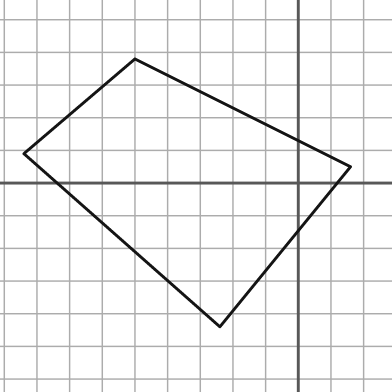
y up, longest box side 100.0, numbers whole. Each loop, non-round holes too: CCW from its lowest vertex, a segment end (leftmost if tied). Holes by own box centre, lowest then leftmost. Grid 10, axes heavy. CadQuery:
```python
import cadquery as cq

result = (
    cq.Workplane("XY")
    .moveTo(-24.0, -44.0)
    .lineTo(16.0, 5.0)
    .lineTo(-50.0, 38.0)
    .lineTo(-84.0, 9.0)
    .close()
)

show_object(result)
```